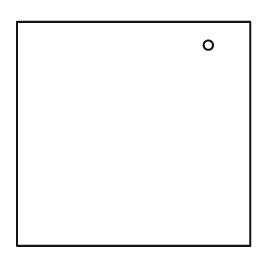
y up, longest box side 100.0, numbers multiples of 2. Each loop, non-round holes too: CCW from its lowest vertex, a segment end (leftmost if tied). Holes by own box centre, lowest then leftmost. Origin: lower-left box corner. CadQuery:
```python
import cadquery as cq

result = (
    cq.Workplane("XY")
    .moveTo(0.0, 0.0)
    .lineTo(100.0, 0.0)
    .lineTo(100.0, 96.0)
    .lineTo(0.0, 96.0)
    .close()
    .moveTo(82.0, 86.0)
    .circle(2.0)
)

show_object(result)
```